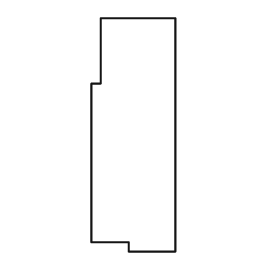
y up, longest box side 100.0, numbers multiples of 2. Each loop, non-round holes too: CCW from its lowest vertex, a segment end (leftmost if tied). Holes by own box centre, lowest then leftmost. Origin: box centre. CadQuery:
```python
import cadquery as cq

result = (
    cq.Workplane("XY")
    .moveTo(-2.0, -50.0)
    .lineTo(18.0, -50.0)
    .lineTo(18.0, 50.0)
    .lineTo(-14.0, 50.0)
    .lineTo(-14.0, 22.0)
    .lineTo(-18.0, 22.0)
    .lineTo(-18.0, -46.0)
    .lineTo(-2.0, -46.0)
    .close()
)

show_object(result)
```